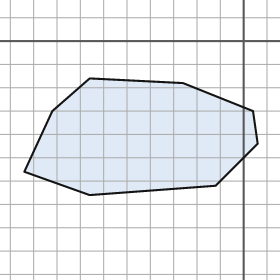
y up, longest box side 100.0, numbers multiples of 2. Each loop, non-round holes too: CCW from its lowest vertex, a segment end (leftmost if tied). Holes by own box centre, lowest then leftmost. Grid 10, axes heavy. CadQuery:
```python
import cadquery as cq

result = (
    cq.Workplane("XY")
    .moveTo(-66.0, -66.0)
    .lineTo(-12.0, -62.0)
    .lineTo(6.0, -44.0)
    .lineTo(4.0, -30.0)
    .lineTo(-26.0, -18.0)
    .lineTo(-66.0, -16.0)
    .lineTo(-82.0, -30.0)
    .lineTo(-94.0, -56.0)
    .close()
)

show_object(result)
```